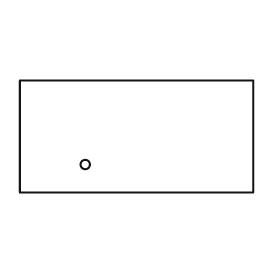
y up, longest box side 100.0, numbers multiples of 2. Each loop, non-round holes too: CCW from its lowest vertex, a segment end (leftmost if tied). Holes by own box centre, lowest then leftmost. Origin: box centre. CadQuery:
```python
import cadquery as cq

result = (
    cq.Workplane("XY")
    .moveTo(-50.0, -24.0)
    .lineTo(50.0, -24.0)
    .lineTo(50.0, 24.0)
    .lineTo(-50.0, 24.0)
    .close()
    .moveTo(-22.0, -12.0)
    .circle(2.0)
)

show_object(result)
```